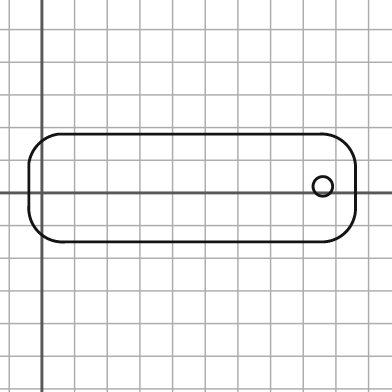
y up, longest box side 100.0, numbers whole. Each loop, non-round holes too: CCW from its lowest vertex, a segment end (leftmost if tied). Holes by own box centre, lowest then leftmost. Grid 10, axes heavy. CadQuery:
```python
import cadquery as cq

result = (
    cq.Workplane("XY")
    .moveTo(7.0, -15.0)
    .lineTo(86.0, -15.0)
    .threePointArc((93.0, -12.0), (96.0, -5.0))
    .lineTo(96.0, 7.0)
    .threePointArc((93.0, 15.0), (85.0, 18.0))
    .lineTo(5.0, 18.0)
    .threePointArc((-1.0, 15.0), (-4.0, 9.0))
    .lineTo(-4.0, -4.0)
    .threePointArc((-1.0, -12.0), (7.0, -15.0))
    .close()
    .moveTo(86.0, 2.0)
    .circle(3.0)
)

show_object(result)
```